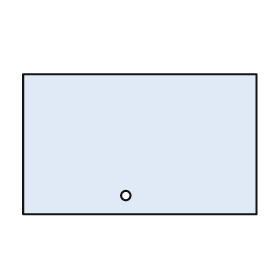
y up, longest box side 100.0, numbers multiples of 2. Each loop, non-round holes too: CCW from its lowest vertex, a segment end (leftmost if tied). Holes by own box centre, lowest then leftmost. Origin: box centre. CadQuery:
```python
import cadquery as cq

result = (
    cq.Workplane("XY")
    .moveTo(-50.0, -30.0)
    .lineTo(50.0, -30.0)
    .lineTo(50.0, 30.0)
    .lineTo(-50.0, 30.0)
    .close()
    .moveTo(-6.0, -22.0)
    .circle(2.0)
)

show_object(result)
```